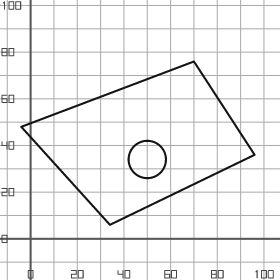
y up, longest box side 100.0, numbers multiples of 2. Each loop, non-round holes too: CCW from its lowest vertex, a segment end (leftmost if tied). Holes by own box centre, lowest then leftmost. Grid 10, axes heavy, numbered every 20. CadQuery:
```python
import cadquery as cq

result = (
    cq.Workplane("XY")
    .moveTo(34.0, 6.0)
    .lineTo(96.0, 36.0)
    .lineTo(70.0, 76.0)
    .lineTo(-4.0, 48.0)
    .close()
    .moveTo(50.0, 34.0)
    .circle(8.0)
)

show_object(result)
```